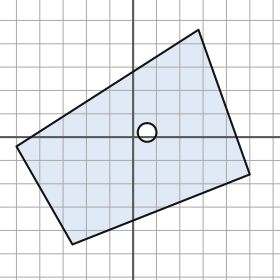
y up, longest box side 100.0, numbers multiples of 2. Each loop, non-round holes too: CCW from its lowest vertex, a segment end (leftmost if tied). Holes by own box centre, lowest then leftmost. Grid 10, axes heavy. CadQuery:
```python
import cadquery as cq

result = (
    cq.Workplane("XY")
    .moveTo(-26.0, -46.0)
    .lineTo(50.0, -16.0)
    .lineTo(28.0, 46.0)
    .lineTo(-50.0, -4.0)
    .close()
    .moveTo(6.0, 2.0)
    .circle(4.0)
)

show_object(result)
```